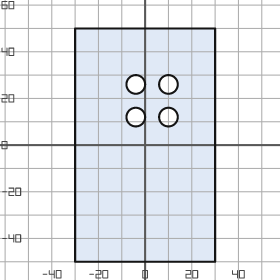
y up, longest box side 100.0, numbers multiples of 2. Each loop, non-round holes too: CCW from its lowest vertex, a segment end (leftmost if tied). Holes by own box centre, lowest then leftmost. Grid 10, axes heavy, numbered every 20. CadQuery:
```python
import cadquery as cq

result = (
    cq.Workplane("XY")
    .moveTo(-30.0, -50.0)
    .lineTo(30.0, -50.0)
    .lineTo(30.0, 50.0)
    .lineTo(-30.0, 50.0)
    .close()
    .moveTo(-4.0, 12.0)
    .circle(4.0)
    .moveTo(10.0, 12.0)
    .circle(4.0)
    .moveTo(-4.0, 26.0)
    .circle(4.0)
    .moveTo(10.0, 26.0)
    .circle(4.0)
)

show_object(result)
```